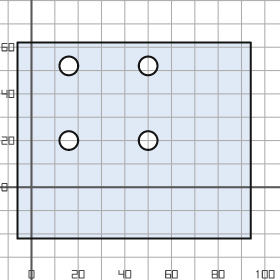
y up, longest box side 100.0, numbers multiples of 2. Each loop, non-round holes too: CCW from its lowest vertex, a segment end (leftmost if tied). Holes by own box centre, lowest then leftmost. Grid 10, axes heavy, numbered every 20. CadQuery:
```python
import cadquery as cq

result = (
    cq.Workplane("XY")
    .moveTo(-6.0, -22.0)
    .lineTo(94.0, -22.0)
    .lineTo(94.0, 62.0)
    .lineTo(-6.0, 62.0)
    .close()
    .moveTo(16.0, 20.0)
    .circle(4.0)
    .moveTo(50.0, 20.0)
    .circle(4.0)
    .moveTo(16.0, 52.0)
    .circle(4.0)
    .moveTo(50.0, 52.0)
    .circle(4.0)
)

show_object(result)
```